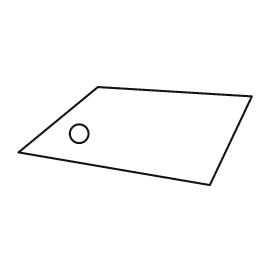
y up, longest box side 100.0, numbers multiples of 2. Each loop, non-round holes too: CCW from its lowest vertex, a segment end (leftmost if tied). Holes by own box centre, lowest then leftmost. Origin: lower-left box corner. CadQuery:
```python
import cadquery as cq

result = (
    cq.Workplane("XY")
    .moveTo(82.0, 0.0)
    .lineTo(100.0, 38.0)
    .lineTo(34.0, 42.0)
    .lineTo(0.0, 14.0)
    .close()
    .moveTo(26.0, 22.0)
    .circle(4.0)
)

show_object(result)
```